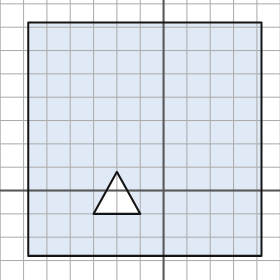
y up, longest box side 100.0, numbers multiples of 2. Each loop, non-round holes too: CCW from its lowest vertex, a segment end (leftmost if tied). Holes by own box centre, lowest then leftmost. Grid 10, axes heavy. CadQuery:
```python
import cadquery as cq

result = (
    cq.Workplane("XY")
    .moveTo(-58.0, -28.0)
    .lineTo(42.0, -28.0)
    .lineTo(42.0, 72.0)
    .lineTo(-58.0, 72.0)
    .close()
    .moveTo(-30.0, -10.0)
    .lineTo(-10.0, -10.0)
    .lineTo(-20.0, 8.0)
    .close()
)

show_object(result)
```